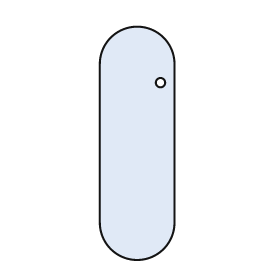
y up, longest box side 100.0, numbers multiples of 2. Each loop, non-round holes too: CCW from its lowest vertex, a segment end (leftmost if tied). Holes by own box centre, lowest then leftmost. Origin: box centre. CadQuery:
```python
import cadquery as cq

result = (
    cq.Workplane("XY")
    .moveTo(-16.0, -34.0)
    .threePointArc((0.0, -50.0), (16.0, -34.0))
    .lineTo(16.0, 34.0)
    .threePointArc((0.0, 50.0), (-16.0, 34.0))
    .close()
    .moveTo(10.0, 26.0)
    .circle(2.0)
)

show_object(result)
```